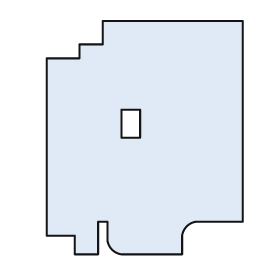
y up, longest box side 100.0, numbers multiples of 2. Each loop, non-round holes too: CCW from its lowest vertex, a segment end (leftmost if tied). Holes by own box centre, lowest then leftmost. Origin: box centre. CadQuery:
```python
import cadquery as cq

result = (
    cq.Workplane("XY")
    .moveTo(-30.0, -50.0)
    .lineTo(-20.0, -50.0)
    .lineTo(-20.0, -36.0)
    .lineTo(-16.0, -36.0)
    .lineTo(-16.0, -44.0)
    .threePointArc((-14.0, -48.0), (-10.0, -50.0))
    .lineTo(16.0, -50.0)
    .lineTo(16.0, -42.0)
    .threePointArc((18.0, -38.0), (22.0, -36.0))
    .lineTo(42.0, -36.0)
    .lineTo(42.0, 50.0)
    .lineTo(-18.0, 50.0)
    .lineTo(-18.0, 40.0)
    .lineTo(-28.0, 40.0)
    .lineTo(-28.0, 34.0)
    .lineTo(-42.0, 34.0)
    .lineTo(-42.0, -42.0)
    .lineTo(-30.0, -42.0)
    .close()
    .moveTo(-10.0, 0.0)
    .lineTo(-2.0, 0.0)
    .lineTo(-2.0, 12.0)
    .lineTo(-10.0, 12.0)
    .close()
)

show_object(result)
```